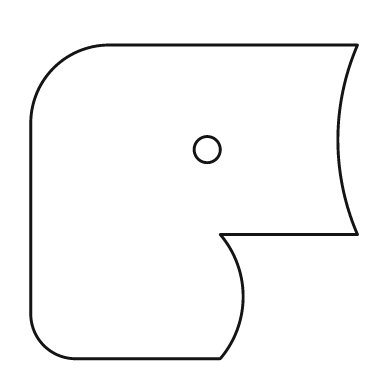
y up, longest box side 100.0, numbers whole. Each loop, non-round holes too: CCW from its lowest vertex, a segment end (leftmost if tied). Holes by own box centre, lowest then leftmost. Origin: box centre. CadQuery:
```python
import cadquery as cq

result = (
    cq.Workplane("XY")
    .moveTo(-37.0, -48.0)
    .lineTo(8.0, -48.0)
    .threePointArc((15.0, -29.0), (8.0, -10.0))
    .lineTo(50.0, -10.0)
    .threePointArc((44.0, 19.0), (50.0, 48.0))
    .lineTo(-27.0, 48.0)
    .threePointArc((-43.0, 41.0), (-50.0, 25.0))
    .lineTo(-50.0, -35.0)
    .threePointArc((-46.0, -44.0), (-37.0, -48.0))
    .close()
    .moveTo(4.0, 16.0)
    .circle(4.0)
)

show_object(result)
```